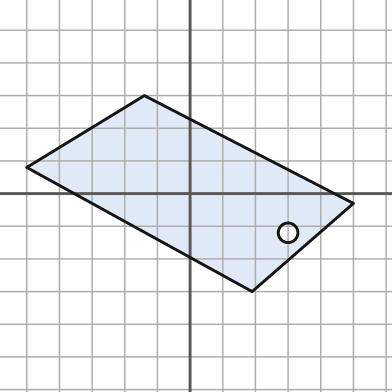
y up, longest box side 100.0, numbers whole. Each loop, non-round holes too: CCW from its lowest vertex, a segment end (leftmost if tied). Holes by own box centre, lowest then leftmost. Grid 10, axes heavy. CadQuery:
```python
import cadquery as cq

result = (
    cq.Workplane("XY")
    .moveTo(19.0, -30.0)
    .lineTo(50.0, -3.0)
    .lineTo(-14.0, 30.0)
    .lineTo(-50.0, 8.0)
    .close()
    .moveTo(30.0, -12.0)
    .circle(3.0)
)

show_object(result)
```